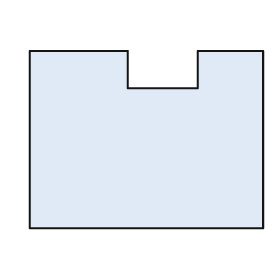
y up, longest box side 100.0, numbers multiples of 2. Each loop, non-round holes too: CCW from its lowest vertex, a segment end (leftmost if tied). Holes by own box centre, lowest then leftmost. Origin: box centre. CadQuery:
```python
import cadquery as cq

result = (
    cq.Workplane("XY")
    .moveTo(-50.0, -38.0)
    .lineTo(50.0, -38.0)
    .lineTo(50.0, 38.0)
    .lineTo(22.0, 38.0)
    .lineTo(22.0, 22.0)
    .lineTo(-8.0, 22.0)
    .lineTo(-8.0, 38.0)
    .lineTo(-50.0, 38.0)
    .close()
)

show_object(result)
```